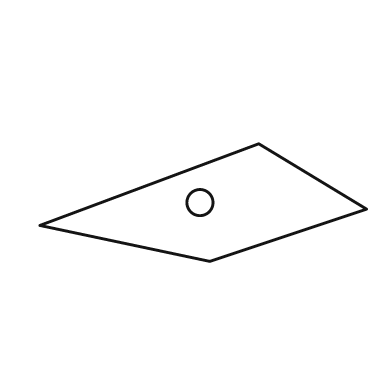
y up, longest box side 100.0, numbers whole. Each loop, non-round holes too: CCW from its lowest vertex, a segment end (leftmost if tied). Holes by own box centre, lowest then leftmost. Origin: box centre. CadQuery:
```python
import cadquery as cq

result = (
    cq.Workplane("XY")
    .moveTo(2.0, -18.0)
    .lineTo(50.0, -2.0)
    .lineTo(17.0, 18.0)
    .lineTo(-50.0, -7.0)
    .close()
    .moveTo(-1.0, 0.0)
    .circle(4.0)
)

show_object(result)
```